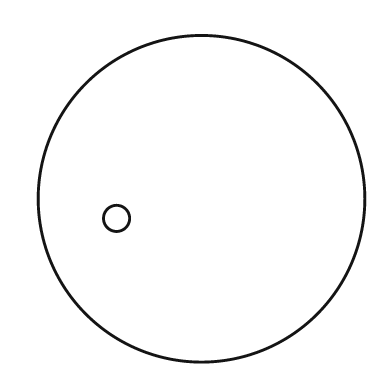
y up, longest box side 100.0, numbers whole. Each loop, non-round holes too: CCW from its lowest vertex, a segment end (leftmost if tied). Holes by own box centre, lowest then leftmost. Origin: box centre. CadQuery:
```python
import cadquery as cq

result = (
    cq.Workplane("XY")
    .moveTo(0.0, 0.0)
    .circle(50.0)
    .moveTo(-26.0, -6.0)
    .circle(4.0)
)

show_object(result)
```